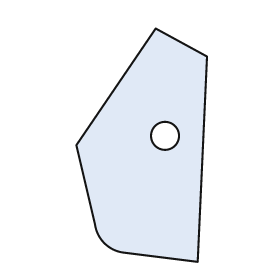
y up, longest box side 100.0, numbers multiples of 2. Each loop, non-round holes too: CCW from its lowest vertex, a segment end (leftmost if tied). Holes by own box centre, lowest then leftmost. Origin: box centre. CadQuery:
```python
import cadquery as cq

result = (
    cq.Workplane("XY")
    .moveTo(24.0, -50.0)
    .lineTo(28.0, 38.0)
    .lineTo(6.0, 50.0)
    .lineTo(-28.0, 0.0)
    .lineTo(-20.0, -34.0)
    .threePointArc((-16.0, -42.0), (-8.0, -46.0))
    .close()
    .moveTo(10.0, 4.0)
    .circle(6.0)
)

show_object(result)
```